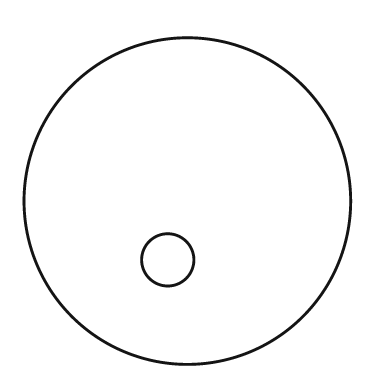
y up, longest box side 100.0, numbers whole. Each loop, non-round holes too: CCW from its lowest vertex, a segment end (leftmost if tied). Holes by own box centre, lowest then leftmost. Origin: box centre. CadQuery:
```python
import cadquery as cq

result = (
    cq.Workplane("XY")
    .moveTo(0.0, 0.0)
    .circle(50.0)
    .moveTo(-6.0, -18.0)
    .circle(8.0)
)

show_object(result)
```